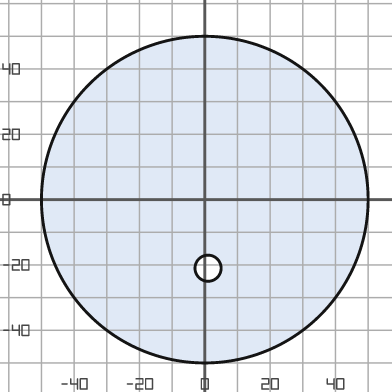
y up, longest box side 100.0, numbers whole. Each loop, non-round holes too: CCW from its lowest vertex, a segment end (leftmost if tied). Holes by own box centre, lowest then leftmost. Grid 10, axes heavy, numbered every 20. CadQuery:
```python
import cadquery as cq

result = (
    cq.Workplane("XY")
    .moveTo(0.0, 0.0)
    .circle(50.0)
    .moveTo(1.0, -21.0)
    .circle(4.0)
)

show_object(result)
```